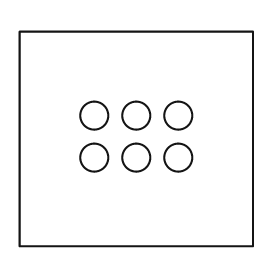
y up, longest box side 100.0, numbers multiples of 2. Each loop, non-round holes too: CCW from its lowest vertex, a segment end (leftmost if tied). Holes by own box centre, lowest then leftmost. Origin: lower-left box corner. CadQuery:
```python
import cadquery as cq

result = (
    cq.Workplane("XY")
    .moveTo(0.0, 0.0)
    .lineTo(100.0, 0.0)
    .lineTo(100.0, 92.0)
    .lineTo(0.0, 92.0)
    .close()
    .moveTo(32.0, 38.0)
    .circle(6.0)
    .moveTo(50.0, 38.0)
    .circle(6.0)
    .moveTo(68.0, 38.0)
    .circle(6.0)
    .moveTo(32.0, 56.0)
    .circle(6.0)
    .moveTo(50.0, 56.0)
    .circle(6.0)
    .moveTo(68.0, 56.0)
    .circle(6.0)
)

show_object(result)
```